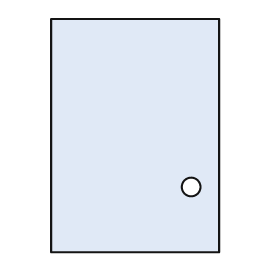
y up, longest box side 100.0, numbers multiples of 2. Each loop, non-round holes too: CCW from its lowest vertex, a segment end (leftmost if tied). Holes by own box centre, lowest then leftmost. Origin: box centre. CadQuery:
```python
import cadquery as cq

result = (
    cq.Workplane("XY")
    .moveTo(-36.0, -50.0)
    .lineTo(36.0, -50.0)
    .lineTo(36.0, 50.0)
    .lineTo(-36.0, 50.0)
    .close()
    .moveTo(24.0, -22.0)
    .circle(4.0)
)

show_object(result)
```